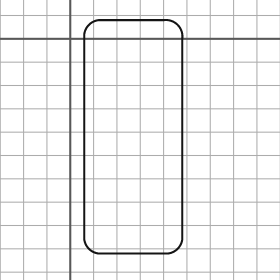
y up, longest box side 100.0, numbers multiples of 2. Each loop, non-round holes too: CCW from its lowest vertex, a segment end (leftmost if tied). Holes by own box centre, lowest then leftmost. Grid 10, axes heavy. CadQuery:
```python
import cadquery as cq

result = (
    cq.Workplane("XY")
    .moveTo(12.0, -92.0)
    .lineTo(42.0, -92.0)
    .threePointArc((46.0, -90.0), (48.0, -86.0))
    .lineTo(48.0, 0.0)
    .threePointArc((46.0, 6.0), (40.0, 8.0))
    .lineTo(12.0, 8.0)
    .threePointArc((8.0, 6.0), (6.0, 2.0))
    .lineTo(6.0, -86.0)
    .threePointArc((8.0, -90.0), (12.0, -92.0))
    .close()
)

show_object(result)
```